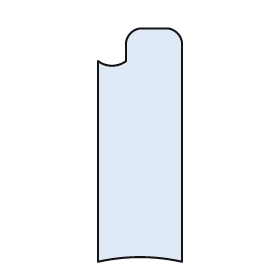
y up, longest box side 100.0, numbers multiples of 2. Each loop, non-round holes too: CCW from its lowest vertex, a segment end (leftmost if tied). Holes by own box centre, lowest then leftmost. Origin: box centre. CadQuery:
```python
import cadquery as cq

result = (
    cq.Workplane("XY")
    .moveTo(-18.0, -50.0)
    .threePointArc((0.0, -48.0), (18.0, -50.0))
    .lineTo(18.0, 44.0)
    .threePointArc((16.0, 48.0), (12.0, 50.0))
    .lineTo(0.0, 50.0)
    .threePointArc((-4.0, 48.0), (-6.0, 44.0))
    .lineTo(-6.0, 36.0)
    .threePointArc((-12.0, 34.0), (-18.0, 36.0))
    .close()
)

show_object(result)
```